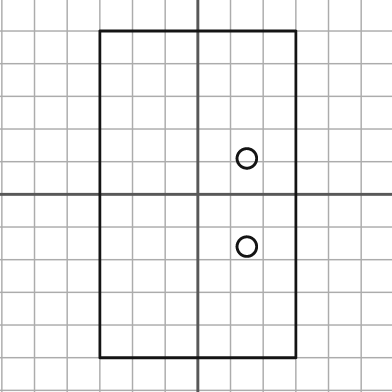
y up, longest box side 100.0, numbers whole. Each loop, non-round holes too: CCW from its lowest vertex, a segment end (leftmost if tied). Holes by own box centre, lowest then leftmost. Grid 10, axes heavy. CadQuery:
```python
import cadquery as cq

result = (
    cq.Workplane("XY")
    .moveTo(-30.0, -50.0)
    .lineTo(30.0, -50.0)
    .lineTo(30.0, 50.0)
    .lineTo(-30.0, 50.0)
    .close()
    .moveTo(15.0, -16.0)
    .circle(3.0)
    .moveTo(15.0, 11.0)
    .circle(3.0)
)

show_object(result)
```